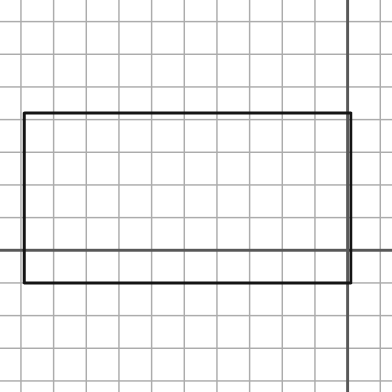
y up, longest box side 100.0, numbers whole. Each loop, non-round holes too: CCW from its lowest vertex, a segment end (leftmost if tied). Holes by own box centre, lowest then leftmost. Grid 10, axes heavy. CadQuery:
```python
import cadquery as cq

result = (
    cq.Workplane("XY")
    .moveTo(-99.0, -10.0)
    .lineTo(1.0, -10.0)
    .lineTo(1.0, 42.0)
    .lineTo(-99.0, 42.0)
    .close()
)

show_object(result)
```